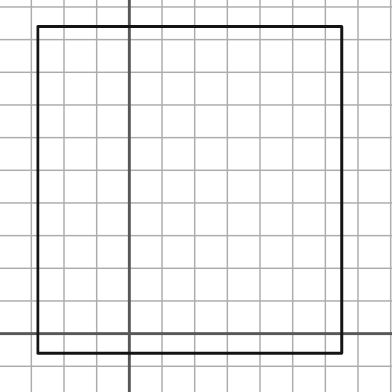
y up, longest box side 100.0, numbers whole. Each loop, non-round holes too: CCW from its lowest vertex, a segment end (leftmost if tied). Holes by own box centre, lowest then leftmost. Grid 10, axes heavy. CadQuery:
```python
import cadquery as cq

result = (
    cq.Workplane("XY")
    .moveTo(-28.0, -6.0)
    .lineTo(65.0, -6.0)
    .lineTo(65.0, 94.0)
    .lineTo(-28.0, 94.0)
    .close()
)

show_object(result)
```